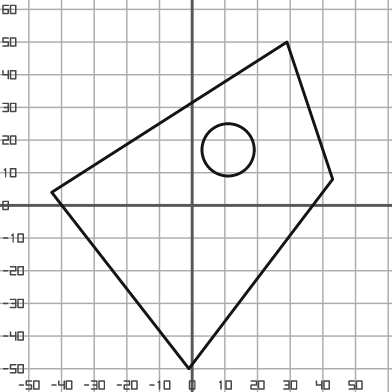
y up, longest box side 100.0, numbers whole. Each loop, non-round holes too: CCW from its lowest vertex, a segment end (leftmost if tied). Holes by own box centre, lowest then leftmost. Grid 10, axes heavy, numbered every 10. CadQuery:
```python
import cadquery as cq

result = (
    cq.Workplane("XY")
    .moveTo(-1.0, -50.0)
    .lineTo(43.0, 8.0)
    .lineTo(29.0, 50.0)
    .lineTo(-43.0, 4.0)
    .close()
    .moveTo(11.0, 17.0)
    .circle(8.0)
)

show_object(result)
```